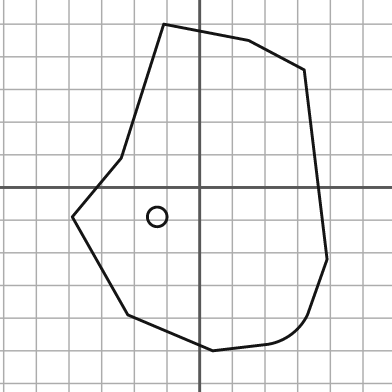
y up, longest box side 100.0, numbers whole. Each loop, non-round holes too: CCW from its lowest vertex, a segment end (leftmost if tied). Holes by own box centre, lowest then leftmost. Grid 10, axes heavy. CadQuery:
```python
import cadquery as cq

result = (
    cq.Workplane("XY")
    .moveTo(4.0, -50.0)
    .lineTo(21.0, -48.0)
    .threePointArc((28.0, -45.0), (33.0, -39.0))
    .lineTo(39.0, -22.0)
    .lineTo(32.0, 36.0)
    .lineTo(15.0, 45.0)
    .lineTo(-11.0, 50.0)
    .lineTo(-24.0, 9.0)
    .lineTo(-39.0, -9.0)
    .lineTo(-22.0, -39.0)
    .close()
    .moveTo(-13.0, -9.0)
    .circle(3.0)
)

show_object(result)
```